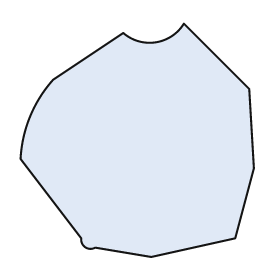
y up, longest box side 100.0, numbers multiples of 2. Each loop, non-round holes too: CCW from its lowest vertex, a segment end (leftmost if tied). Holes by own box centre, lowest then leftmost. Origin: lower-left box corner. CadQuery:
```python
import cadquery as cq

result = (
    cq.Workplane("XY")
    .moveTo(56.0, 0.0)
    .lineTo(92.0, 8.0)
    .lineTo(100.0, 38.0)
    .lineTo(98.0, 72.0)
    .lineTo(70.0, 100.0)
    .threePointArc((58.0, 92.0), (44.0, 96.0))
    .lineTo(14.0, 76.0)
    .threePointArc((4.0, 60.0), (0.0, 42.0))
    .lineTo(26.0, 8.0)
    .threePointArc((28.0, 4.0), (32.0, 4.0))
    .close()
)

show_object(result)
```